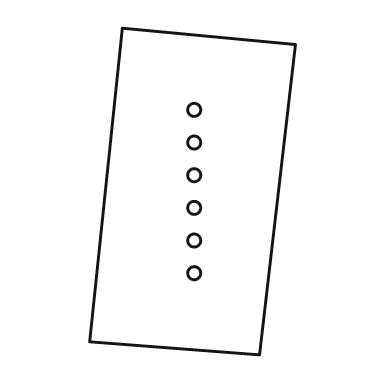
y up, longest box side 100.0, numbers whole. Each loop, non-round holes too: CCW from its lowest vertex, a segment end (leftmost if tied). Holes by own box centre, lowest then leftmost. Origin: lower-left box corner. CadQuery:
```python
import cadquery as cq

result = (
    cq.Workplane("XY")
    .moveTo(52.0, 0.0)
    .lineTo(63.0, 95.0)
    .lineTo(10.0, 100.0)
    .lineTo(0.0, 4.0)
    .close()
    .moveTo(32.0, 25.0)
    .circle(2.0)
    .moveTo(32.0, 35.0)
    .circle(2.0)
    .moveTo(32.0, 45.0)
    .circle(2.0)
    .moveTo(32.0, 55.0)
    .circle(2.0)
    .moveTo(32.0, 65.0)
    .circle(2.0)
    .moveTo(32.0, 75.0)
    .circle(2.0)
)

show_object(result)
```